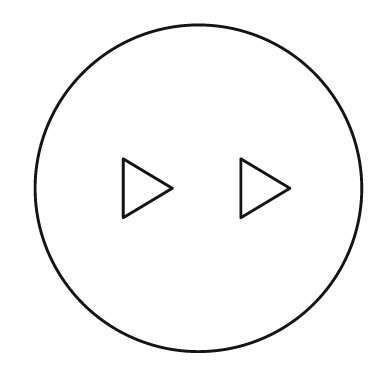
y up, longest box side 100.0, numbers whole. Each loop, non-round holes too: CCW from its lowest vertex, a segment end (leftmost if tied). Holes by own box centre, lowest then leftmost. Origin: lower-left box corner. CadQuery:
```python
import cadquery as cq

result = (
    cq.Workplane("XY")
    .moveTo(50.0, 50.0)
    .circle(50.0)
    .moveTo(27.0, 41.0)
    .lineTo(42.0, 50.0)
    .lineTo(27.0, 59.0)
    .close()
    .moveTo(63.0, 41.0)
    .lineTo(78.0, 50.0)
    .lineTo(63.0, 59.0)
    .close()
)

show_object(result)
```